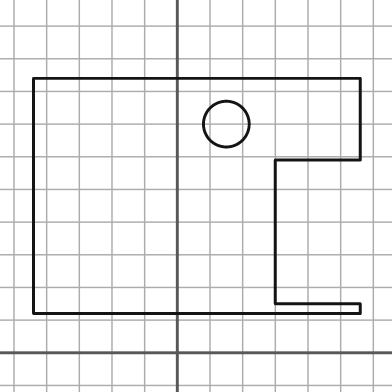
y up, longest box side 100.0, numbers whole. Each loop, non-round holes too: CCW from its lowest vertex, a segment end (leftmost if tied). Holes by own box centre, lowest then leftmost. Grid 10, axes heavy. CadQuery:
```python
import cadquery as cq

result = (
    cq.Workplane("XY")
    .moveTo(-44.0, 12.0)
    .lineTo(56.0, 12.0)
    .lineTo(56.0, 15.0)
    .lineTo(30.0, 15.0)
    .lineTo(30.0, 59.0)
    .lineTo(56.0, 59.0)
    .lineTo(56.0, 84.0)
    .lineTo(-44.0, 84.0)
    .close()
    .moveTo(15.0, 70.0)
    .circle(7.0)
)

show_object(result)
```